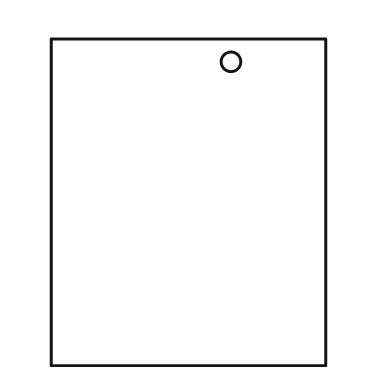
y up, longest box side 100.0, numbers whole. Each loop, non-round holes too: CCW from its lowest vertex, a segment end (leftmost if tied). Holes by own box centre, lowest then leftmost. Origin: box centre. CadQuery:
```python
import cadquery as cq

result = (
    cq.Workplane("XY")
    .moveTo(-42.0, -50.0)
    .lineTo(42.0, -50.0)
    .lineTo(42.0, 50.0)
    .lineTo(-42.0, 50.0)
    .close()
    .moveTo(13.0, 43.0)
    .circle(3.0)
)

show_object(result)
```